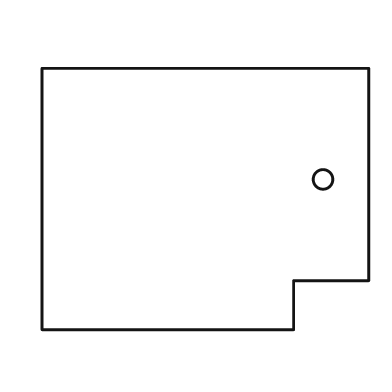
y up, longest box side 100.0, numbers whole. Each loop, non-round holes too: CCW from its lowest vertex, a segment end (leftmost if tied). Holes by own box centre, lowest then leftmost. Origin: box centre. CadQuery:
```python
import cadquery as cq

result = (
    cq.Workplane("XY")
    .moveTo(-50.0, -40.0)
    .lineTo(27.0, -40.0)
    .lineTo(27.0, -25.0)
    .lineTo(50.0, -25.0)
    .lineTo(50.0, 40.0)
    .lineTo(-50.0, 40.0)
    .close()
    .moveTo(36.0, 6.0)
    .circle(3.0)
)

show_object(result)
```